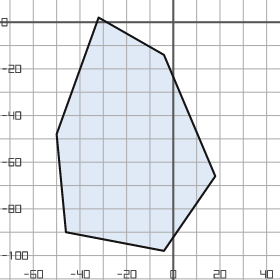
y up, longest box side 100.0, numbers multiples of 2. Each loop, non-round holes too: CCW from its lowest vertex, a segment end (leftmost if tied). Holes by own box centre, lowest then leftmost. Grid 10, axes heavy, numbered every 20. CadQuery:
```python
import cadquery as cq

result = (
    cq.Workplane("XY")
    .moveTo(-4.0, -98.0)
    .lineTo(18.0, -66.0)
    .lineTo(-4.0, -14.0)
    .lineTo(-32.0, 2.0)
    .lineTo(-50.0, -48.0)
    .lineTo(-46.0, -90.0)
    .close()
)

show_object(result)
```